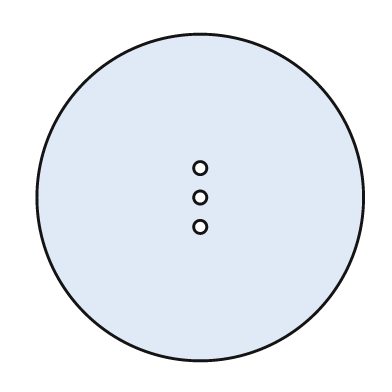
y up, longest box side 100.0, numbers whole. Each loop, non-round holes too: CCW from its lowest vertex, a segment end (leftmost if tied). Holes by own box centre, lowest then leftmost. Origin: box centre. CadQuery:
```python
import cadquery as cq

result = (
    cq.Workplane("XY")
    .moveTo(0.0, 0.0)
    .circle(50.0)
    .moveTo(0.0, -9.0)
    .circle(2.0)
    .moveTo(0.0, 0.0)
    .circle(2.0)
    .moveTo(0.0, 9.0)
    .circle(2.0)
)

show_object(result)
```